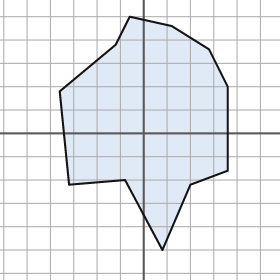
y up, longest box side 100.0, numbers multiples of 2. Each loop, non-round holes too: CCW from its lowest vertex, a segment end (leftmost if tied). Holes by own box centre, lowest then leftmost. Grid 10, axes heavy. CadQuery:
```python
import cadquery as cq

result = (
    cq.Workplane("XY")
    .moveTo(8.0, -50.0)
    .lineTo(20.0, -22.0)
    .lineTo(36.0, -16.0)
    .lineTo(36.0, 20.0)
    .lineTo(28.0, 36.0)
    .lineTo(12.0, 46.0)
    .lineTo(-6.0, 50.0)
    .lineTo(-12.0, 38.0)
    .lineTo(-36.0, 18.0)
    .lineTo(-32.0, -22.0)
    .lineTo(-8.0, -20.0)
    .close()
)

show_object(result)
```